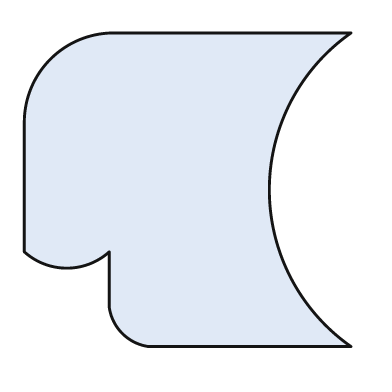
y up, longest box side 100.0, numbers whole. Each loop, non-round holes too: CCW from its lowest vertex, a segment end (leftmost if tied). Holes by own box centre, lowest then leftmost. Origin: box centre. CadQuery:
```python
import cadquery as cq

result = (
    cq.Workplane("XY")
    .moveTo(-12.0, -48.0)
    .lineTo(50.0, -48.0)
    .threePointArc((25.0, 0.0), (50.0, 48.0))
    .lineTo(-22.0, 48.0)
    .threePointArc((-42.0, 40.0), (-50.0, 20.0))
    .lineTo(-50.0, -19.0)
    .threePointArc((-37.0, -24.0), (-24.0, -19.0))
    .lineTo(-24.0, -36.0)
    .threePointArc((-20.0, -44.0), (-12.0, -48.0))
    .close()
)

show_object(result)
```